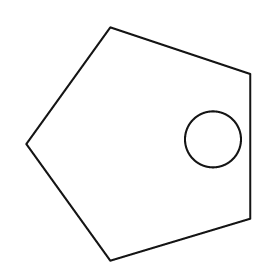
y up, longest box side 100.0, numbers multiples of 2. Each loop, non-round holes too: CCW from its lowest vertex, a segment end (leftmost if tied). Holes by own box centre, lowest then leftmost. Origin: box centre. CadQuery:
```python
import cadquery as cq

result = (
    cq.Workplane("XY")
    .moveTo(-12.0, -50.0)
    .lineTo(48.0, -32.0)
    .lineTo(48.0, 30.0)
    .lineTo(-12.0, 50.0)
    .lineTo(-48.0, 0.0)
    .close()
    .moveTo(32.0, 2.0)
    .circle(12.0)
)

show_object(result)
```